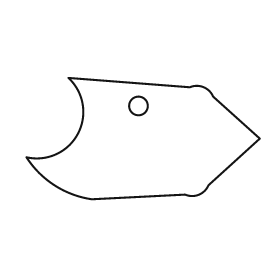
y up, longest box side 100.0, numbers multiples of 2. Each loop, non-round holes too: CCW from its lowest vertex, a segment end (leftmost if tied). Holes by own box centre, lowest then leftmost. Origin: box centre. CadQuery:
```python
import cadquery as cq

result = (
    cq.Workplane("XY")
    .moveTo(-22.0, -26.0)
    .lineTo(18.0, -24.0)
    .threePointArc((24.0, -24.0), (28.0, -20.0))
    .lineTo(50.0, 0.0)
    .lineTo(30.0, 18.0)
    .threePointArc((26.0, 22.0), (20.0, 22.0))
    .lineTo(-32.0, 26.0)
    .threePointArc((-28.0, 2.0), (-50.0, -8.0))
    .threePointArc((-38.0, -20.0), (-22.0, -26.0))
    .close()
    .moveTo(-2.0, 14.0)
    .circle(4.0)
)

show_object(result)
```